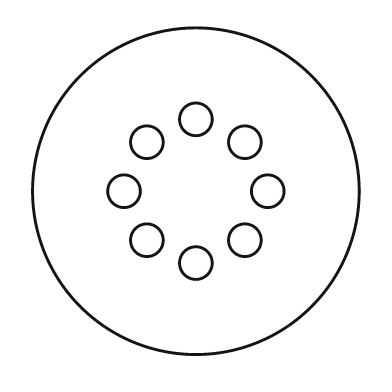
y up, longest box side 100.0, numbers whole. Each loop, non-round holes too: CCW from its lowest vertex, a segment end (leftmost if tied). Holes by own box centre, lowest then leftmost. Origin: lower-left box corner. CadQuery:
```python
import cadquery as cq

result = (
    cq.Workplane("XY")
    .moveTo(50.0, 50.0)
    .circle(50.0)
    .moveTo(50.0, 28.0)
    .circle(5.0)
    .moveTo(35.0, 35.0)
    .circle(5.0)
    .moveTo(65.0, 35.0)
    .circle(5.0)
    .moveTo(28.0, 50.0)
    .circle(5.0)
    .moveTo(72.0, 50.0)
    .circle(5.0)
    .moveTo(35.0, 65.0)
    .circle(5.0)
    .moveTo(65.0, 65.0)
    .circle(5.0)
    .moveTo(50.0, 72.0)
    .circle(5.0)
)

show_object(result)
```